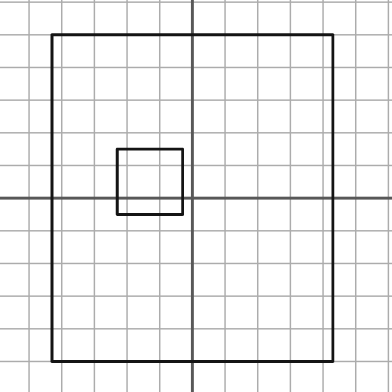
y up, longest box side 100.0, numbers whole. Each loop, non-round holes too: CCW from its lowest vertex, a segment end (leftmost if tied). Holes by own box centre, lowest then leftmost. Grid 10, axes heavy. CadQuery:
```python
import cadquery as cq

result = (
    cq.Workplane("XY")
    .moveTo(-43.0, -50.0)
    .lineTo(43.0, -50.0)
    .lineTo(43.0, 50.0)
    .lineTo(-43.0, 50.0)
    .close()
    .moveTo(-23.0, -5.0)
    .lineTo(-3.0, -5.0)
    .lineTo(-3.0, 15.0)
    .lineTo(-23.0, 15.0)
    .close()
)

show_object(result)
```